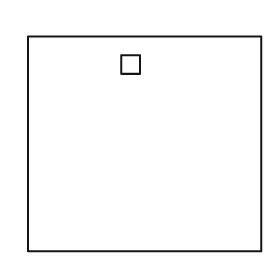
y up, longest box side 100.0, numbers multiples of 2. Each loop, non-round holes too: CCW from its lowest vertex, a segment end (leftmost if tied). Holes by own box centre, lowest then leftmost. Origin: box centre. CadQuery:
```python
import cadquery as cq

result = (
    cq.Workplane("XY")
    .moveTo(-50.0, -46.0)
    .lineTo(50.0, -46.0)
    .lineTo(50.0, 46.0)
    .lineTo(-50.0, 46.0)
    .close()
    .moveTo(-10.0, 30.0)
    .lineTo(-2.0, 30.0)
    .lineTo(-2.0, 38.0)
    .lineTo(-10.0, 38.0)
    .close()
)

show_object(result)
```